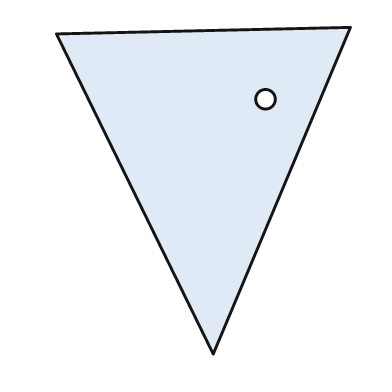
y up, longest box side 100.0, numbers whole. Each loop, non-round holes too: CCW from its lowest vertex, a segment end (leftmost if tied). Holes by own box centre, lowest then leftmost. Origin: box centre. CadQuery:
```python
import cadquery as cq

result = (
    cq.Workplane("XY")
    .moveTo(3.0, -50.0)
    .lineTo(45.0, 50.0)
    .lineTo(-45.0, 48.0)
    .close()
    .moveTo(19.0, 28.0)
    .circle(3.0)
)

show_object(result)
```